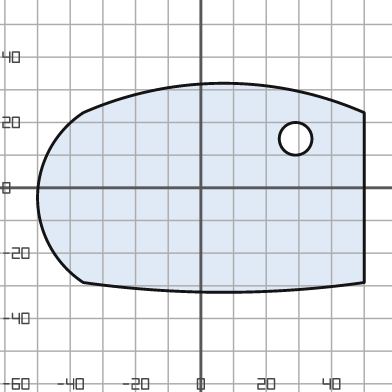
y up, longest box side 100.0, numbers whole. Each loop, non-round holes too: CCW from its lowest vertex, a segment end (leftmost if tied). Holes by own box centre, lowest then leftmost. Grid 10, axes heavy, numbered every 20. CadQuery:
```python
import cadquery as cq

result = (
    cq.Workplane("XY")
    .moveTo(-36.0, -29.0)
    .threePointArc((7.0, -32.0), (50.0, -29.0))
    .lineTo(50.0, 23.0)
    .threePointArc((7.0, 32.0), (-36.0, 23.0))
    .threePointArc((-50.0, -3.0), (-36.0, -29.0))
    .close()
    .moveTo(29.0, 15.0)
    .circle(5.0)
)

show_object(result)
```